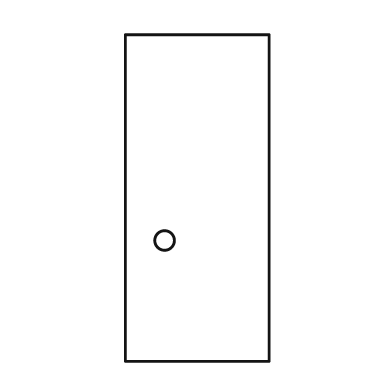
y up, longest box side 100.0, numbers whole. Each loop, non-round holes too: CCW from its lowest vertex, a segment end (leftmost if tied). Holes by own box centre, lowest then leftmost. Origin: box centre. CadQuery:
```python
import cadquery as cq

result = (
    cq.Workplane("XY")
    .moveTo(-22.0, -50.0)
    .lineTo(22.0, -50.0)
    .lineTo(22.0, 50.0)
    .lineTo(-22.0, 50.0)
    .close()
    .moveTo(-10.0, -13.0)
    .circle(3.0)
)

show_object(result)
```